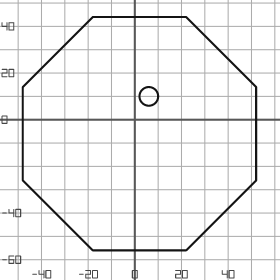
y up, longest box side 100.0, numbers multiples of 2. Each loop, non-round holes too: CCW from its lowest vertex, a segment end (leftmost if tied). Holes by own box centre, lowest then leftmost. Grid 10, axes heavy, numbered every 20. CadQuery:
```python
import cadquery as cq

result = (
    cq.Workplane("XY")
    .moveTo(-18.0, -56.0)
    .lineTo(22.0, -56.0)
    .lineTo(52.0, -26.0)
    .lineTo(52.0, 14.0)
    .lineTo(22.0, 44.0)
    .lineTo(-18.0, 44.0)
    .lineTo(-48.0, 14.0)
    .lineTo(-48.0, -26.0)
    .close()
    .moveTo(6.0, 10.0)
    .circle(4.0)
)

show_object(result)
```